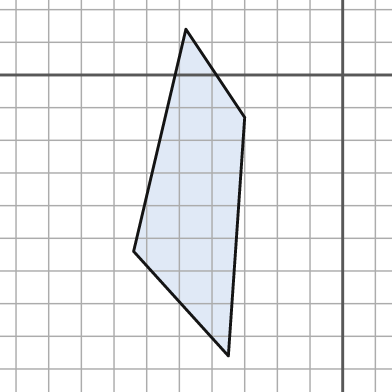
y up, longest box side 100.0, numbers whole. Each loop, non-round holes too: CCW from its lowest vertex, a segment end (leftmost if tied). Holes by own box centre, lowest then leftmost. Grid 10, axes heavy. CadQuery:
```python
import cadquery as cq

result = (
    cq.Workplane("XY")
    .moveTo(-35.0, -86.0)
    .lineTo(-30.0, -13.0)
    .lineTo(-48.0, 14.0)
    .lineTo(-64.0, -54.0)
    .close()
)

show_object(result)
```